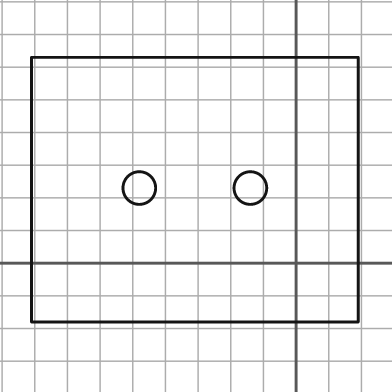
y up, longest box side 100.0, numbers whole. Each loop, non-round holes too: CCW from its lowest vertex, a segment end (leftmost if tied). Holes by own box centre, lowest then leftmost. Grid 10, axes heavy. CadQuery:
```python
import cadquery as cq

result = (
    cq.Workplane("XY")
    .moveTo(-81.0, -18.0)
    .lineTo(19.0, -18.0)
    .lineTo(19.0, 63.0)
    .lineTo(-81.0, 63.0)
    .close()
    .moveTo(-48.0, 23.0)
    .circle(5.0)
    .moveTo(-14.0, 23.0)
    .circle(5.0)
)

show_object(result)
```